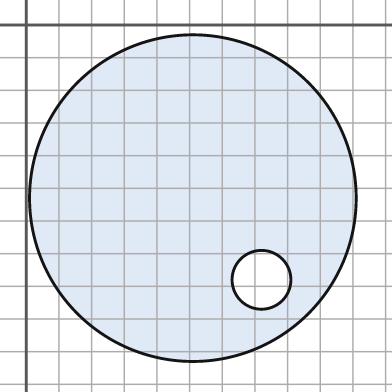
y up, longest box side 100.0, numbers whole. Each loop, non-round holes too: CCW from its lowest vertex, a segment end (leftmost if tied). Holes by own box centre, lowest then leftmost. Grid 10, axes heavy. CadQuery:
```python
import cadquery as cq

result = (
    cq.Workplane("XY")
    .moveTo(51.0, -53.0)
    .circle(50.0)
    .moveTo(72.0, -78.0)
    .circle(9.0)
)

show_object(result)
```